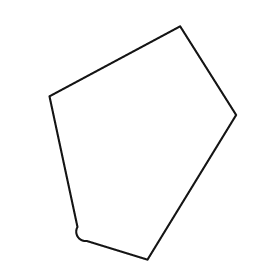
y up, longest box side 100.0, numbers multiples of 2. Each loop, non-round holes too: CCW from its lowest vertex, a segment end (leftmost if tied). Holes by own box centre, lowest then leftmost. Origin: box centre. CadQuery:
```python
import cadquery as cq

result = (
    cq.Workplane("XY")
    .moveTo(2.0, -50.0)
    .lineTo(40.0, 12.0)
    .lineTo(16.0, 50.0)
    .lineTo(-40.0, 20.0)
    .lineTo(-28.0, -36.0)
    .threePointArc((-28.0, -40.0), (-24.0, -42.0))
    .close()
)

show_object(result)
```